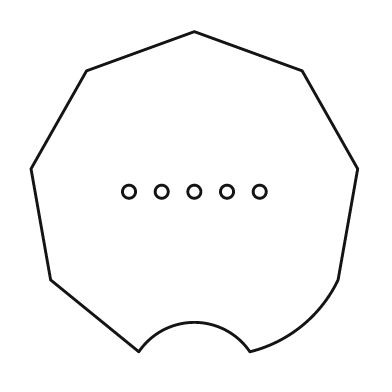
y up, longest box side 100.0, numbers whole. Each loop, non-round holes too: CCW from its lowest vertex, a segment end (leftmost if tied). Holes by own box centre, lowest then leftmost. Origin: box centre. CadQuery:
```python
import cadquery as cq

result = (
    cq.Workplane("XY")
    .moveTo(-17.0, -49.0)
    .threePointArc((0.0, -40.0), (17.0, -49.0))
    .threePointArc((33.0, -41.0), (44.0, -27.0))
    .lineTo(50.0, 7.0)
    .lineTo(33.0, 37.0)
    .lineTo(0.0, 49.0)
    .lineTo(-33.0, 37.0)
    .lineTo(-50.0, 7.0)
    .lineTo(-44.0, -27.0)
    .close()
    .moveTo(-20.0, 0.0)
    .circle(2.0)
    .moveTo(-10.0, 0.0)
    .circle(2.0)
    .moveTo(0.0, 0.0)
    .circle(2.0)
    .moveTo(10.0, 0.0)
    .circle(2.0)
    .moveTo(20.0, 0.0)
    .circle(2.0)
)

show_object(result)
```